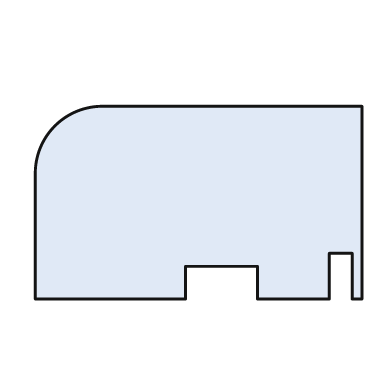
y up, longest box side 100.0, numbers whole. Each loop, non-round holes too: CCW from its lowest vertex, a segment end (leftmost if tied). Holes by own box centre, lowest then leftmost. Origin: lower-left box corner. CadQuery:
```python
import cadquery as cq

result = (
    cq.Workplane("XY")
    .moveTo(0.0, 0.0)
    .lineTo(46.0, 0.0)
    .lineTo(46.0, 10.0)
    .lineTo(68.0, 10.0)
    .lineTo(68.0, 0.0)
    .lineTo(90.0, 0.0)
    .lineTo(90.0, 14.0)
    .lineTo(97.0, 14.0)
    .lineTo(97.0, 0.0)
    .lineTo(100.0, 0.0)
    .lineTo(100.0, 59.0)
    .lineTo(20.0, 59.0)
    .threePointArc((6.0, 53.0), (0.0, 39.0))
    .close()
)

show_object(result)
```